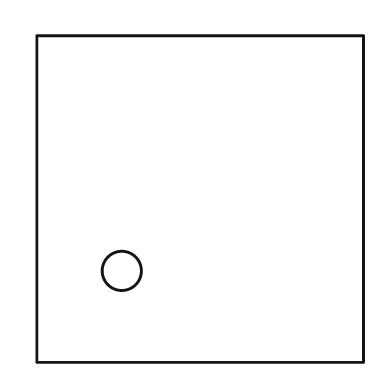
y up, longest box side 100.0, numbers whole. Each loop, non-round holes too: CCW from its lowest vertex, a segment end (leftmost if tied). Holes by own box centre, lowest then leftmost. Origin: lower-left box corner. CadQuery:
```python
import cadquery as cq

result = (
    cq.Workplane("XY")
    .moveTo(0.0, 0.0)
    .lineTo(100.0, 0.0)
    .lineTo(100.0, 100.0)
    .lineTo(0.0, 100.0)
    .close()
    .moveTo(26.0, 28.0)
    .circle(6.0)
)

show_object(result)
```